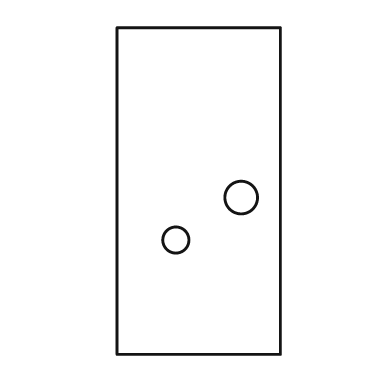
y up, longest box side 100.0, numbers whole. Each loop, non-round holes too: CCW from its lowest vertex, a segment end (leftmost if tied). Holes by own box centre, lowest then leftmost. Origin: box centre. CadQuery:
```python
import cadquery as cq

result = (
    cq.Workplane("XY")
    .moveTo(-25.0, -50.0)
    .lineTo(25.0, -50.0)
    .lineTo(25.0, 50.0)
    .lineTo(-25.0, 50.0)
    .close()
    .moveTo(-7.0, -15.0)
    .circle(4.0)
    .moveTo(13.0, -2.0)
    .circle(5.0)
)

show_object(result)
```